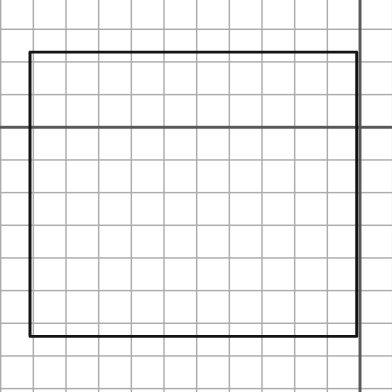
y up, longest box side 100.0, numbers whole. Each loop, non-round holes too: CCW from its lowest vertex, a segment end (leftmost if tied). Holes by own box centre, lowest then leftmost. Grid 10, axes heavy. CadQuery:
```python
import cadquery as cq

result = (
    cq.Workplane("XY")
    .moveTo(-101.0, -64.0)
    .lineTo(-1.0, -64.0)
    .lineTo(-1.0, 23.0)
    .lineTo(-101.0, 23.0)
    .close()
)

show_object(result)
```